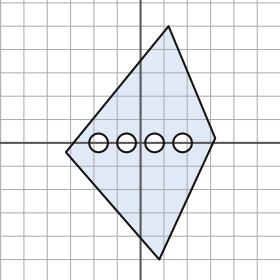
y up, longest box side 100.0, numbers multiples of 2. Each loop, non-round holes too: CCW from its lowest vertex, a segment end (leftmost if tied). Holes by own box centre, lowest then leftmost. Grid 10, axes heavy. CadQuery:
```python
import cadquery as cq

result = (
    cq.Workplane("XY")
    .moveTo(8.0, -50.0)
    .lineTo(32.0, 2.0)
    .lineTo(12.0, 50.0)
    .lineTo(-32.0, -4.0)
    .close()
    .moveTo(-18.0, 0.0)
    .circle(4.0)
    .moveTo(-6.0, 0.0)
    .circle(4.0)
    .moveTo(6.0, 0.0)
    .circle(4.0)
    .moveTo(18.0, 0.0)
    .circle(4.0)
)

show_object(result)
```